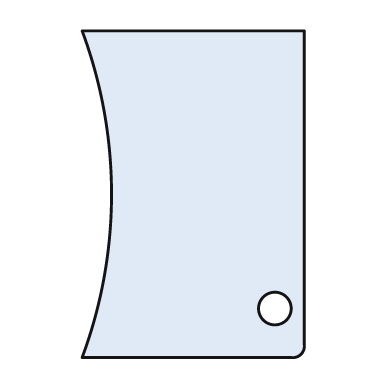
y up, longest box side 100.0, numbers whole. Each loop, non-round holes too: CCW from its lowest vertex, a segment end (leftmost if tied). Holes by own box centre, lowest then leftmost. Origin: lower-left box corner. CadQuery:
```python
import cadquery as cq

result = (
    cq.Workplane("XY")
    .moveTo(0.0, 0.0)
    .lineTo(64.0, 0.0)
    .threePointArc((67.0, 1.0), (68.0, 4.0))
    .lineTo(68.0, 100.0)
    .lineTo(0.0, 100.0)
    .threePointArc((9.0, 50.0), (0.0, 0.0))
    .close()
    .moveTo(59.0, 15.0)
    .circle(5.0)
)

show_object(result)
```